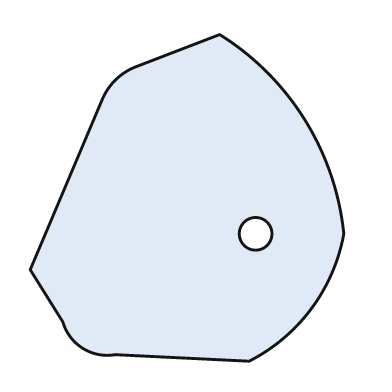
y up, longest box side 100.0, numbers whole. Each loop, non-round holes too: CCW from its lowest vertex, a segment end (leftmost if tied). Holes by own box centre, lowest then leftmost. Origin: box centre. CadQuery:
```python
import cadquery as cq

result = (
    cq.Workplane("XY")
    .moveTo(19.0, -50.0)
    .threePointArc((38.0, -34.0), (48.0, -11.0))
    .threePointArc((36.0, 24.0), (10.0, 50.0))
    .lineTo(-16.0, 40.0)
    .threePointArc((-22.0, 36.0), (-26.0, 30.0))
    .lineTo(-48.0, -22.0)
    .lineTo(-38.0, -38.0)
    .threePointArc((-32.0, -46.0), (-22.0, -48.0))
    .close()
    .moveTo(21.0, -11.0)
    .circle(5.0)
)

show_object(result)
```